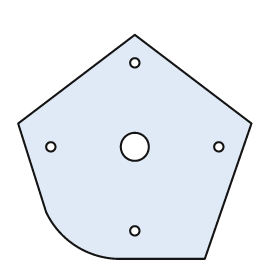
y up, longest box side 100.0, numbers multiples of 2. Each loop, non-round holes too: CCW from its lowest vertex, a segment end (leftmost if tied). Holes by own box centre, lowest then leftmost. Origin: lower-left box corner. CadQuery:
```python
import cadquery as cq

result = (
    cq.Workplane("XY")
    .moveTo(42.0, 0.0)
    .lineTo(80.0, 0.0)
    .lineTo(100.0, 58.0)
    .lineTo(50.0, 96.0)
    .lineTo(0.0, 58.0)
    .lineTo(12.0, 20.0)
    .threePointArc((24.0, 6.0), (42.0, 0.0))
    .close()
    .moveTo(50.0, 12.0)
    .circle(2.0)
    .moveTo(14.0, 48.0)
    .circle(2.0)
    .moveTo(50.0, 48.0)
    .circle(6.0)
    .moveTo(86.0, 48.0)
    .circle(2.0)
    .moveTo(50.0, 84.0)
    .circle(2.0)
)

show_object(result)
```